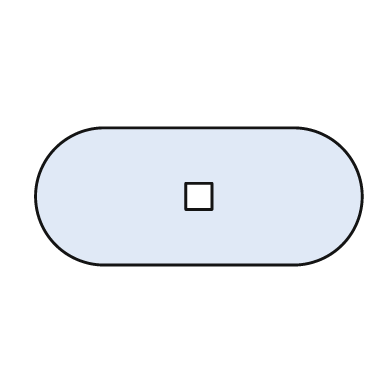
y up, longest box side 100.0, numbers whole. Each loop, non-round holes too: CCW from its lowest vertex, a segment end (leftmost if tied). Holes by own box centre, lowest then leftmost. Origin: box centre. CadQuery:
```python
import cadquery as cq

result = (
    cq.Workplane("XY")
    .moveTo(-29.0, -21.0)
    .lineTo(29.0, -21.0)
    .threePointArc((50.0, 0.0), (29.0, 21.0))
    .lineTo(-29.0, 21.0)
    .threePointArc((-50.0, 0.0), (-29.0, -21.0))
    .close()
    .moveTo(-4.0, -4.0)
    .lineTo(4.0, -4.0)
    .lineTo(4.0, 4.0)
    .lineTo(-4.0, 4.0)
    .close()
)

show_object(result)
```